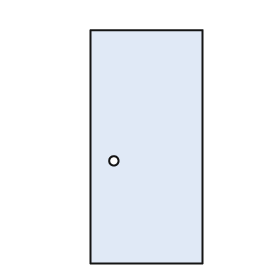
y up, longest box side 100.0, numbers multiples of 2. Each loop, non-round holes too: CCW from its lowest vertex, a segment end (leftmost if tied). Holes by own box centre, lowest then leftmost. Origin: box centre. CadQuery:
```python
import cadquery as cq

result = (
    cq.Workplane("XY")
    .moveTo(-24.0, -50.0)
    .lineTo(24.0, -50.0)
    .lineTo(24.0, 50.0)
    .lineTo(-24.0, 50.0)
    .close()
    .moveTo(-14.0, -6.0)
    .circle(2.0)
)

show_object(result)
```